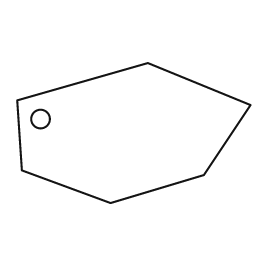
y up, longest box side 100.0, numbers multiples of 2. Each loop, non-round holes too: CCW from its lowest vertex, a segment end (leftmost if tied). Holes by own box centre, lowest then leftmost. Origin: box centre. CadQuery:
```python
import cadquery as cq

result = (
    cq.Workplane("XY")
    .moveTo(-10.0, -30.0)
    .lineTo(30.0, -18.0)
    .lineTo(50.0, 12.0)
    .lineTo(6.0, 30.0)
    .lineTo(-50.0, 14.0)
    .lineTo(-48.0, -16.0)
    .close()
    .moveTo(-40.0, 6.0)
    .circle(4.0)
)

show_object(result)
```